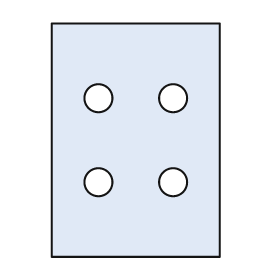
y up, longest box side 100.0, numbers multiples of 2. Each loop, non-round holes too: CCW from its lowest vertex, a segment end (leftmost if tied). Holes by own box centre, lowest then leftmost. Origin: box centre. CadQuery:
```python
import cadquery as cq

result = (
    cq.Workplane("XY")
    .moveTo(-36.0, -50.0)
    .lineTo(36.0, -50.0)
    .lineTo(36.0, 50.0)
    .lineTo(-36.0, 50.0)
    .close()
    .moveTo(-16.0, -18.0)
    .circle(6.0)
    .moveTo(16.0, -18.0)
    .circle(6.0)
    .moveTo(-16.0, 18.0)
    .circle(6.0)
    .moveTo(16.0, 18.0)
    .circle(6.0)
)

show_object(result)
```